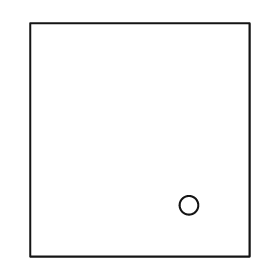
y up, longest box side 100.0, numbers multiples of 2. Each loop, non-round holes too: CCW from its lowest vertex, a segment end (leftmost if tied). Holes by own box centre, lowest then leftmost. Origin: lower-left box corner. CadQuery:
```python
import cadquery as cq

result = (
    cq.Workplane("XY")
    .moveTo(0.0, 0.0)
    .lineTo(94.0, 0.0)
    .lineTo(94.0, 100.0)
    .lineTo(0.0, 100.0)
    .close()
    .moveTo(68.0, 22.0)
    .circle(4.0)
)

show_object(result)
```